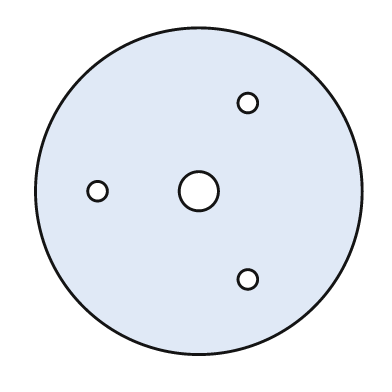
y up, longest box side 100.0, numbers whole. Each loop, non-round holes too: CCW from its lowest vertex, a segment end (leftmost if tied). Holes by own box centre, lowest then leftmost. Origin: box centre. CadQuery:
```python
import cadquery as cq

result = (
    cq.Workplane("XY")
    .moveTo(0.0, 0.0)
    .circle(50.0)
    .moveTo(15.0, -27.0)
    .circle(3.0)
    .moveTo(-31.0, 0.0)
    .circle(3.0)
    .moveTo(0.0, 0.0)
    .circle(6.0)
    .moveTo(15.0, 27.0)
    .circle(3.0)
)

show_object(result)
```